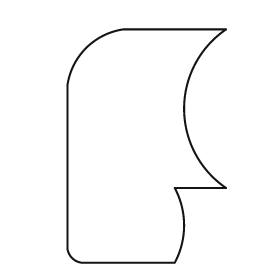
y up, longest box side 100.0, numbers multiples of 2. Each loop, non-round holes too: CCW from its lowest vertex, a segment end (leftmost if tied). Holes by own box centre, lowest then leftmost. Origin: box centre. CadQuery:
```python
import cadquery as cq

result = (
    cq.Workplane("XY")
    .moveTo(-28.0, -50.0)
    .lineTo(12.0, -50.0)
    .threePointArc((16.0, -34.0), (12.0, -18.0))
    .lineTo(34.0, -18.0)
    .threePointArc((16.0, 16.0), (34.0, 50.0))
    .lineTo(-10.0, 50.0)
    .threePointArc((-26.0, 42.0), (-34.0, 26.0))
    .lineTo(-34.0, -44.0)
    .threePointArc((-32.0, -48.0), (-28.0, -50.0))
    .close()
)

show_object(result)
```